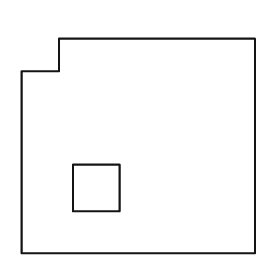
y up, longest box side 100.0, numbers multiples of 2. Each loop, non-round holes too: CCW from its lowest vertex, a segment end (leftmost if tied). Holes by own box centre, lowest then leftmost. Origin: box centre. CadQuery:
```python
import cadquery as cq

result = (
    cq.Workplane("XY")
    .moveTo(-50.0, -46.0)
    .lineTo(50.0, -46.0)
    .lineTo(50.0, 46.0)
    .lineTo(-34.0, 46.0)
    .lineTo(-34.0, 32.0)
    .lineTo(-50.0, 32.0)
    .close()
    .moveTo(-28.0, -28.0)
    .lineTo(-8.0, -28.0)
    .lineTo(-8.0, -8.0)
    .lineTo(-28.0, -8.0)
    .close()
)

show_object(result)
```